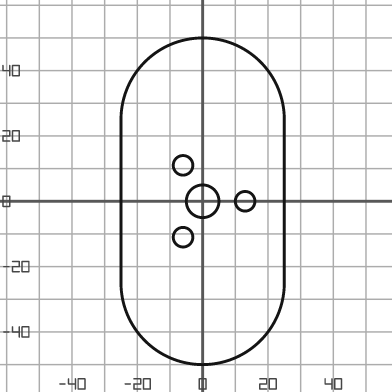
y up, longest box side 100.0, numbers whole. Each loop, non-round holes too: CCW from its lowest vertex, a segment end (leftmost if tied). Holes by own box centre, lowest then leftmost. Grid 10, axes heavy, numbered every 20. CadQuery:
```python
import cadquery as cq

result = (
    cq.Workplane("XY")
    .moveTo(-25.0, -25.0)
    .threePointArc((0.0, -50.0), (25.0, -25.0))
    .lineTo(25.0, 25.0)
    .threePointArc((0.0, 50.0), (-25.0, 25.0))
    .close()
    .moveTo(-6.0, -11.0)
    .circle(3.0)
    .moveTo(0.0, 0.0)
    .circle(5.0)
    .moveTo(13.0, 0.0)
    .circle(3.0)
    .moveTo(-6.0, 11.0)
    .circle(3.0)
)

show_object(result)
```